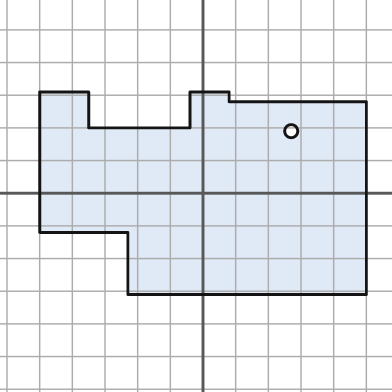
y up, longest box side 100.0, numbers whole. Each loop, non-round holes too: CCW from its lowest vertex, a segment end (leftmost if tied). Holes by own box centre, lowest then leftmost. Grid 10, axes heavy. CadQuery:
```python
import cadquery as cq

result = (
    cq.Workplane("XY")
    .moveTo(-23.0, -31.0)
    .lineTo(50.0, -31.0)
    .lineTo(50.0, 28.0)
    .lineTo(8.0, 28.0)
    .lineTo(8.0, 31.0)
    .lineTo(-4.0, 31.0)
    .lineTo(-4.0, 20.0)
    .lineTo(-35.0, 20.0)
    .lineTo(-35.0, 31.0)
    .lineTo(-50.0, 31.0)
    .lineTo(-50.0, -12.0)
    .lineTo(-23.0, -12.0)
    .close()
    .moveTo(27.0, 19.0)
    .circle(2.0)
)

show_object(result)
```